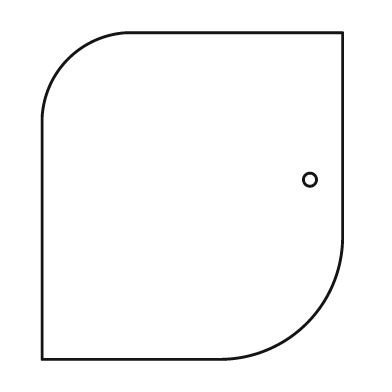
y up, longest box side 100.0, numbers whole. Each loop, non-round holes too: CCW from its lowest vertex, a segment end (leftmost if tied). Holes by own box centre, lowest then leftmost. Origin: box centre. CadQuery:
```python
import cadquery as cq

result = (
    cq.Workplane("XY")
    .moveTo(-46.0, -50.0)
    .lineTo(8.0, -50.0)
    .threePointArc((35.0, -39.0), (46.0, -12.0))
    .lineTo(46.0, 50.0)
    .lineTo(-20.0, 50.0)
    .threePointArc((-38.0, 42.0), (-46.0, 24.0))
    .close()
    .moveTo(36.0, 5.0)
    .circle(2.0)
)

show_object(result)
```